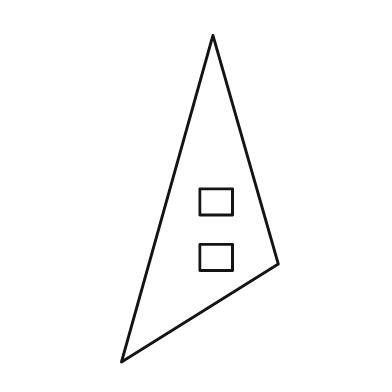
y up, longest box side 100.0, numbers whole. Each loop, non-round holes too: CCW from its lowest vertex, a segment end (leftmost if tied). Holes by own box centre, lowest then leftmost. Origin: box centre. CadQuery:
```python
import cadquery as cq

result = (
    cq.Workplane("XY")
    .moveTo(-24.0, -50.0)
    .lineTo(24.0, -20.0)
    .lineTo(4.0, 50.0)
    .close()
    .moveTo(0.0, -22.0)
    .lineTo(10.0, -22.0)
    .lineTo(10.0, -14.0)
    .lineTo(0.0, -14.0)
    .close()
    .moveTo(0.0, -5.0)
    .lineTo(10.0, -5.0)
    .lineTo(10.0, 3.0)
    .lineTo(0.0, 3.0)
    .close()
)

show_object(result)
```